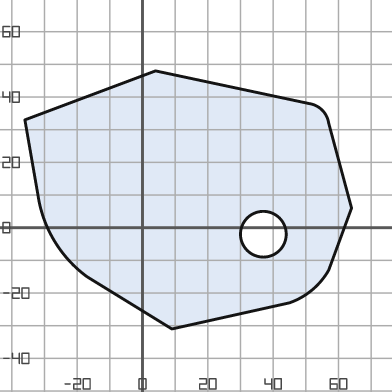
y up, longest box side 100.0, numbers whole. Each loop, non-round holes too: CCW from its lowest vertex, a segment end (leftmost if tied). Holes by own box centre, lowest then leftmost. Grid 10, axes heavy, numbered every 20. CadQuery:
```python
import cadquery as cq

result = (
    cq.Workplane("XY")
    .moveTo(9.0, -31.0)
    .lineTo(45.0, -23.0)
    .threePointArc((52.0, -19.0), (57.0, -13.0))
    .lineTo(64.0, 6.0)
    .lineTo(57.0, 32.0)
    .threePointArc((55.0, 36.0), (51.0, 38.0))
    .lineTo(4.0, 48.0)
    .lineTo(-36.0, 33.0)
    .lineTo(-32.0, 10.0)
    .threePointArc((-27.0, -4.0), (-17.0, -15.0))
    .close()
    .moveTo(37.0, -2.0)
    .circle(7.0)
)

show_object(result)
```